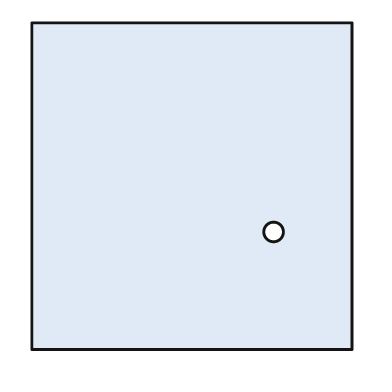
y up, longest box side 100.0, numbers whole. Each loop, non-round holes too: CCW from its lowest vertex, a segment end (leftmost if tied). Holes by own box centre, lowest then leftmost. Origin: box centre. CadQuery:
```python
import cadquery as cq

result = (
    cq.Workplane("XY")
    .moveTo(-49.0, -50.0)
    .lineTo(49.0, -50.0)
    .lineTo(49.0, 50.0)
    .lineTo(-49.0, 50.0)
    .close()
    .moveTo(25.0, -14.0)
    .circle(3.0)
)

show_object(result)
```